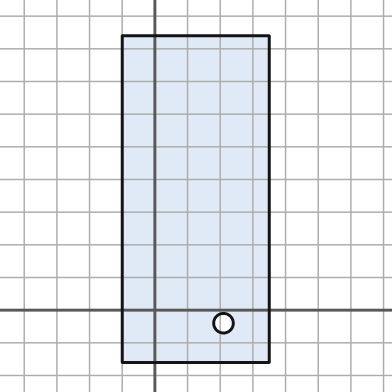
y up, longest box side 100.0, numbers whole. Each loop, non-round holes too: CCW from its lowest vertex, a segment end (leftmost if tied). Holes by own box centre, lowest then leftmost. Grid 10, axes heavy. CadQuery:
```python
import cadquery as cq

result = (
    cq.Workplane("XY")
    .moveTo(-10.0, -16.0)
    .lineTo(35.0, -16.0)
    .lineTo(35.0, 84.0)
    .lineTo(-10.0, 84.0)
    .close()
    .moveTo(21.0, -4.0)
    .circle(3.0)
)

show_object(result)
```